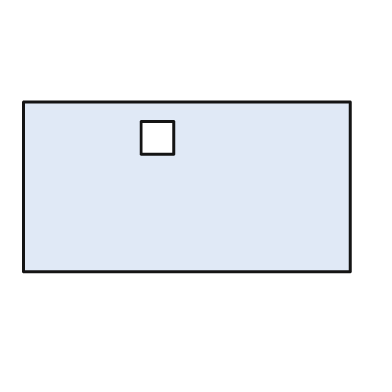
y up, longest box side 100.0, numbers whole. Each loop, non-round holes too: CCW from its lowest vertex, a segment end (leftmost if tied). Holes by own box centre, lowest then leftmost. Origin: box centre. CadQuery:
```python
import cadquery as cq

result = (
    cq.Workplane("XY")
    .moveTo(-50.0, -26.0)
    .lineTo(50.0, -26.0)
    .lineTo(50.0, 26.0)
    .lineTo(-50.0, 26.0)
    .close()
    .moveTo(-14.0, 10.0)
    .lineTo(-4.0, 10.0)
    .lineTo(-4.0, 20.0)
    .lineTo(-14.0, 20.0)
    .close()
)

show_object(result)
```